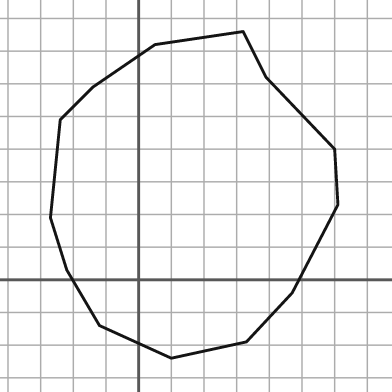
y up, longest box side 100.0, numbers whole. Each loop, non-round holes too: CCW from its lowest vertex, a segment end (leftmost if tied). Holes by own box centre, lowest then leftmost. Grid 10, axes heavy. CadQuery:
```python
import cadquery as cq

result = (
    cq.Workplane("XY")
    .moveTo(10.0, -24.0)
    .lineTo(33.0, -19.0)
    .lineTo(47.0, -4.0)
    .lineTo(61.0, 23.0)
    .lineTo(60.0, 40.0)
    .lineTo(39.0, 62.0)
    .lineTo(32.0, 76.0)
    .lineTo(5.0, 72.0)
    .lineTo(-14.0, 59.0)
    .lineTo(-24.0, 49.0)
    .lineTo(-27.0, 19.0)
    .lineTo(-22.0, 3.0)
    .lineTo(-12.0, -14.0)
    .close()
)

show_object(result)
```